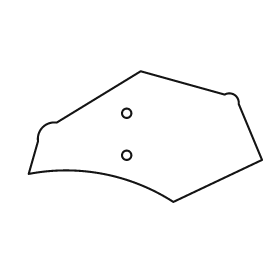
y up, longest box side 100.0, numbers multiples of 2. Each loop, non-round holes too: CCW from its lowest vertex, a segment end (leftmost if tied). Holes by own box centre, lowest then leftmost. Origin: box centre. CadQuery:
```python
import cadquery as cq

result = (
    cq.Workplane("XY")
    .moveTo(12.0, -28.0)
    .lineTo(50.0, -10.0)
    .lineTo(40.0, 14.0)
    .threePointArc((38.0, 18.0), (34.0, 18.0))
    .lineTo(-2.0, 28.0)
    .lineTo(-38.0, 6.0)
    .threePointArc((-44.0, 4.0), (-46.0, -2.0))
    .lineTo(-50.0, -16.0)
    .threePointArc((-18.0, -16.0), (12.0, -28.0))
    .close()
    .moveTo(-8.0, -8.0)
    .circle(2.0)
    .moveTo(-8.0, 10.0)
    .circle(2.0)
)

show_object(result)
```